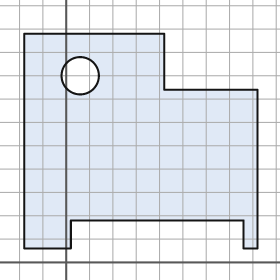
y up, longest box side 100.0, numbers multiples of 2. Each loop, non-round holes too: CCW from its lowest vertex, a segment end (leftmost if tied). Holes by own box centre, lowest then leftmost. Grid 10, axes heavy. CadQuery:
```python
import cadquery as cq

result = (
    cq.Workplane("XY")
    .moveTo(-18.0, 6.0)
    .lineTo(2.0, 6.0)
    .lineTo(2.0, 18.0)
    .lineTo(76.0, 18.0)
    .lineTo(76.0, 6.0)
    .lineTo(82.0, 6.0)
    .lineTo(82.0, 74.0)
    .lineTo(42.0, 74.0)
    .lineTo(42.0, 98.0)
    .lineTo(-18.0, 98.0)
    .close()
    .moveTo(6.0, 80.0)
    .circle(8.0)
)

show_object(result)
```